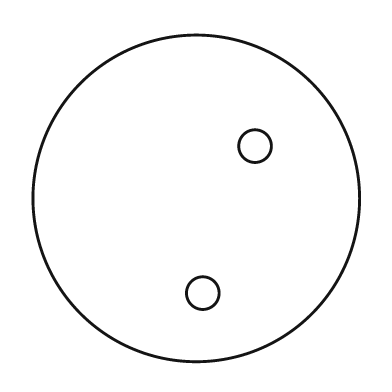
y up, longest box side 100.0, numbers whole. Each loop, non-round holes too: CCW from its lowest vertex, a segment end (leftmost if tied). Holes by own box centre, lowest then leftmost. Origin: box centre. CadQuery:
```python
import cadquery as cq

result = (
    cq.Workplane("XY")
    .moveTo(0.0, 0.0)
    .circle(50.0)
    .moveTo(2.0, -29.0)
    .circle(5.0)
    .moveTo(18.0, 16.0)
    .circle(5.0)
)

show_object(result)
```